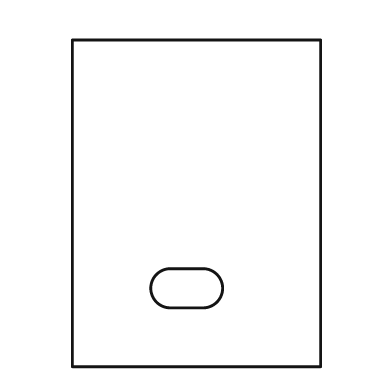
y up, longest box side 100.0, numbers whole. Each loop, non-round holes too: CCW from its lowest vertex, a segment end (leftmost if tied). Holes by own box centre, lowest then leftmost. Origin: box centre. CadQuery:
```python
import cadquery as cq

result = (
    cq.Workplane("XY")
    .moveTo(-38.0, -50.0)
    .lineTo(38.0, -50.0)
    .lineTo(38.0, 50.0)
    .lineTo(-38.0, 50.0)
    .close()
    .moveTo(-8.0, -32.0)
    .lineTo(2.0, -32.0)
    .threePointArc((8.0, -26.0), (2.0, -20.0))
    .lineTo(-8.0, -20.0)
    .threePointArc((-14.0, -26.0), (-8.0, -32.0))
    .close()
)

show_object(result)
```